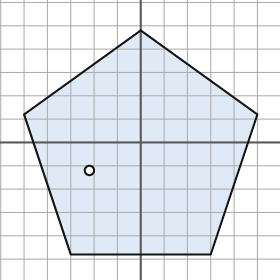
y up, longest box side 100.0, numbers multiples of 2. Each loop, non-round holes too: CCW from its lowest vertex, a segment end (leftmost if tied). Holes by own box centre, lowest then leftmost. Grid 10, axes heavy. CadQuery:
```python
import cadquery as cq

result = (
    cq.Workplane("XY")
    .moveTo(-30.0, -48.0)
    .lineTo(30.0, -48.0)
    .lineTo(50.0, 12.0)
    .lineTo(0.0, 48.0)
    .lineTo(-50.0, 12.0)
    .close()
    .moveTo(-22.0, -12.0)
    .circle(2.0)
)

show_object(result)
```